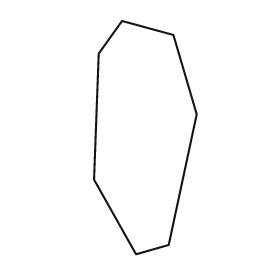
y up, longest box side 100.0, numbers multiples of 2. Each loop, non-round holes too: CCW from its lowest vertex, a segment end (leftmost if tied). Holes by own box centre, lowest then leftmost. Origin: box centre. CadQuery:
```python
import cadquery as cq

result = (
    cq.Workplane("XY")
    .moveTo(-4.0, -50.0)
    .lineTo(10.0, -46.0)
    .lineTo(22.0, 10.0)
    .lineTo(12.0, 44.0)
    .lineTo(-10.0, 50.0)
    .lineTo(-20.0, 36.0)
    .lineTo(-22.0, -18.0)
    .close()
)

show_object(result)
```